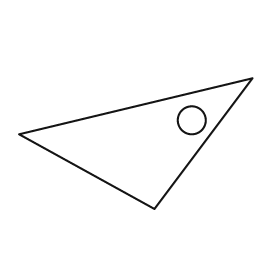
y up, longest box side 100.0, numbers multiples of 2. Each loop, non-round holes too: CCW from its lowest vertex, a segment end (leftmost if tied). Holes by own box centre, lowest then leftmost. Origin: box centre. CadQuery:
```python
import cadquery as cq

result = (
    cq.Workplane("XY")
    .moveTo(8.0, -28.0)
    .lineTo(50.0, 28.0)
    .lineTo(-50.0, 4.0)
    .close()
    .moveTo(24.0, 10.0)
    .circle(6.0)
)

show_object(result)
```